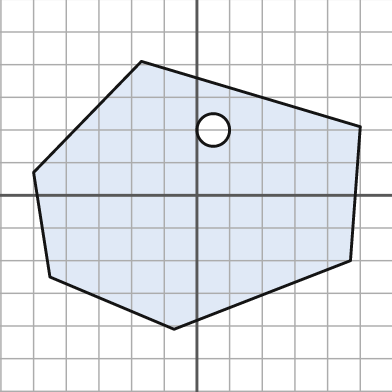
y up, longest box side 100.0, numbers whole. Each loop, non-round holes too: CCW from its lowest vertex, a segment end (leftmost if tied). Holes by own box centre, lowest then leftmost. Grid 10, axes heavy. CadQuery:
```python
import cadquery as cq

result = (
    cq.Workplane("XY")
    .moveTo(-7.0, -41.0)
    .lineTo(47.0, -20.0)
    .lineTo(50.0, 21.0)
    .lineTo(-17.0, 41.0)
    .lineTo(-50.0, 7.0)
    .lineTo(-45.0, -25.0)
    .close()
    .moveTo(5.0, 20.0)
    .circle(5.0)
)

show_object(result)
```